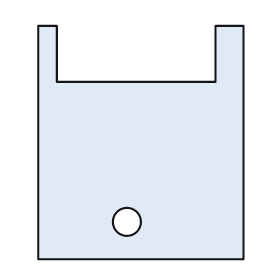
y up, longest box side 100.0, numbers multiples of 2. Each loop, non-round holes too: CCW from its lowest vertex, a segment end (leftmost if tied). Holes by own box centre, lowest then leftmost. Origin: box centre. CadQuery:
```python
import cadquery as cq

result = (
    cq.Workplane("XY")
    .moveTo(-44.0, -50.0)
    .lineTo(44.0, -50.0)
    .lineTo(44.0, 50.0)
    .lineTo(32.0, 50.0)
    .lineTo(32.0, 26.0)
    .lineTo(-36.0, 26.0)
    .lineTo(-36.0, 50.0)
    .lineTo(-44.0, 50.0)
    .close()
    .moveTo(-6.0, -34.0)
    .circle(6.0)
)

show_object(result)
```